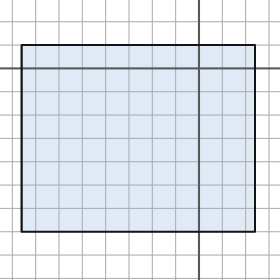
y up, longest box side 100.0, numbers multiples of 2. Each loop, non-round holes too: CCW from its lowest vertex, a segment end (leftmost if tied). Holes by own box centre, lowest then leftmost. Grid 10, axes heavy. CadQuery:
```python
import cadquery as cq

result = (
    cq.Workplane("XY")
    .moveTo(-76.0, -70.0)
    .lineTo(24.0, -70.0)
    .lineTo(24.0, 10.0)
    .lineTo(-76.0, 10.0)
    .close()
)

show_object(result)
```